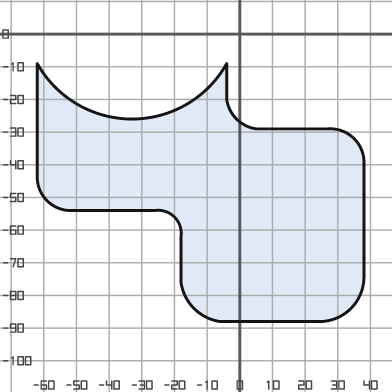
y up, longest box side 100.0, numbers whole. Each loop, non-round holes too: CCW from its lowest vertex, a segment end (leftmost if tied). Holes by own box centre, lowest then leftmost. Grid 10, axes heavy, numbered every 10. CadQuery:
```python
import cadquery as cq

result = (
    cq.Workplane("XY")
    .moveTo(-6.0, -88.0)
    .lineTo(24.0, -88.0)
    .threePointArc((34.0, -84.0), (38.0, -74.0))
    .lineTo(38.0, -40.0)
    .threePointArc((35.0, -32.0), (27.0, -29.0))
    .lineTo(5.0, -29.0)
    .threePointArc((-1.0, -26.0), (-4.0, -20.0))
    .lineTo(-4.0, -9.0)
    .threePointArc((-33.0, -26.0), (-62.0, -9.0))
    .lineTo(-62.0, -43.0)
    .threePointArc((-59.0, -51.0), (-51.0, -54.0))
    .lineTo(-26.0, -54.0)
    .threePointArc((-20.0, -56.0), (-18.0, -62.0))
    .lineTo(-18.0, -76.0)
    .threePointArc((-14.0, -84.0), (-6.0, -88.0))
    .close()
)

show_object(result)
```